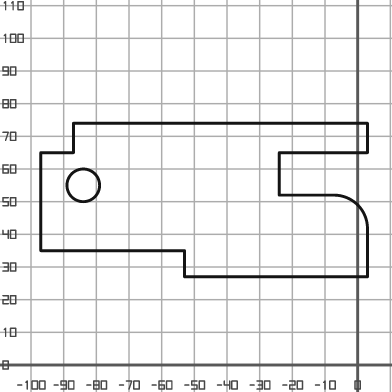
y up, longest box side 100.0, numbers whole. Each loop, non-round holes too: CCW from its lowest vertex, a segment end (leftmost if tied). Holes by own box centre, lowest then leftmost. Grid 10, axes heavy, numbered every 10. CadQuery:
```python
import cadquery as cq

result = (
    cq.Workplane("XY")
    .moveTo(-53.0, 27.0)
    .lineTo(3.0, 27.0)
    .lineTo(3.0, 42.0)
    .threePointArc((0.0, 49.0), (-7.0, 52.0))
    .lineTo(-24.0, 52.0)
    .lineTo(-24.0, 65.0)
    .lineTo(3.0, 65.0)
    .lineTo(3.0, 74.0)
    .lineTo(-87.0, 74.0)
    .lineTo(-87.0, 65.0)
    .lineTo(-97.0, 65.0)
    .lineTo(-97.0, 35.0)
    .lineTo(-53.0, 35.0)
    .close()
    .moveTo(-84.0, 55.0)
    .circle(5.0)
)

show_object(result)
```